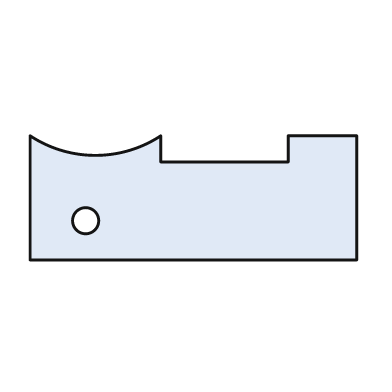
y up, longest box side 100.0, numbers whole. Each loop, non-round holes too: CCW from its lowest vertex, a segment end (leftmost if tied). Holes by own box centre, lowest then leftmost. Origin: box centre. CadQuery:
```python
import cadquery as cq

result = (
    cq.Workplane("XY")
    .moveTo(-50.0, -19.0)
    .lineTo(50.0, -19.0)
    .lineTo(50.0, 19.0)
    .lineTo(29.0, 19.0)
    .lineTo(29.0, 11.0)
    .lineTo(-10.0, 11.0)
    .lineTo(-10.0, 19.0)
    .threePointArc((-30.0, 13.0), (-50.0, 19.0))
    .close()
    .moveTo(-33.0, -7.0)
    .circle(4.0)
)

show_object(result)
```